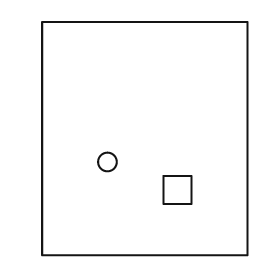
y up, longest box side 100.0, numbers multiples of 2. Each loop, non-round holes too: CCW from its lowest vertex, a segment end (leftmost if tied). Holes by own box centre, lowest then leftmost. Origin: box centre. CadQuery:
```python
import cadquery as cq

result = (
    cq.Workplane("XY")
    .moveTo(-44.0, -50.0)
    .lineTo(44.0, -50.0)
    .lineTo(44.0, 50.0)
    .lineTo(-44.0, 50.0)
    .close()
    .moveTo(8.0, -28.0)
    .lineTo(20.0, -28.0)
    .lineTo(20.0, -16.0)
    .lineTo(8.0, -16.0)
    .close()
    .moveTo(-16.0, -10.0)
    .circle(4.0)
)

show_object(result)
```